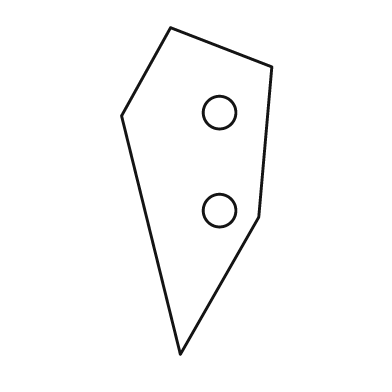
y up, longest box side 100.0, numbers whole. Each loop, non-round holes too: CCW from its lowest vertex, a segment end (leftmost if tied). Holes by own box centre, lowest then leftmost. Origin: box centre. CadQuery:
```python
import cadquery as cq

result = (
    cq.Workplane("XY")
    .moveTo(-5.0, -50.0)
    .lineTo(19.0, -8.0)
    .lineTo(23.0, 38.0)
    .lineTo(-8.0, 50.0)
    .lineTo(-23.0, 23.0)
    .close()
    .moveTo(7.0, -6.0)
    .circle(5.0)
    .moveTo(7.0, 24.0)
    .circle(5.0)
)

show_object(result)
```